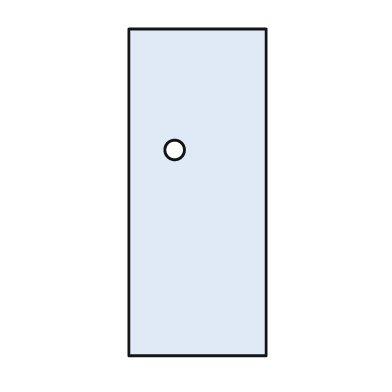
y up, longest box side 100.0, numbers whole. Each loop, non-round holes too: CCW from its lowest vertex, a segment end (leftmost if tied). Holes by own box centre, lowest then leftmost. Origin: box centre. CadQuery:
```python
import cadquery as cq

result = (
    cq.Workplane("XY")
    .moveTo(-21.0, -50.0)
    .lineTo(21.0, -50.0)
    .lineTo(21.0, 50.0)
    .lineTo(-21.0, 50.0)
    .close()
    .moveTo(-7.0, 13.0)
    .circle(3.0)
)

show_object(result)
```